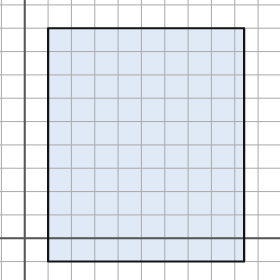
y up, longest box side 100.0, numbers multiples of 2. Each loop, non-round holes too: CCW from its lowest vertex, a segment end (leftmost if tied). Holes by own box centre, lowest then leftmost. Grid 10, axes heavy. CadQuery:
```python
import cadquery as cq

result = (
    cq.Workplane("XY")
    .moveTo(10.0, -10.0)
    .lineTo(94.0, -10.0)
    .lineTo(94.0, 90.0)
    .lineTo(10.0, 90.0)
    .close()
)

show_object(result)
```